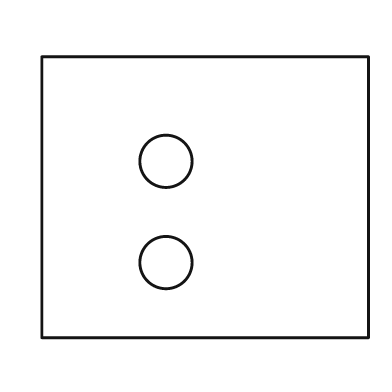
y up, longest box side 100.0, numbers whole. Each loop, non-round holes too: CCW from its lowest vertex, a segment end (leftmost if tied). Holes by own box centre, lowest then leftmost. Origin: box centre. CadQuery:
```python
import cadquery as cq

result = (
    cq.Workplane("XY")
    .moveTo(-50.0, -43.0)
    .lineTo(50.0, -43.0)
    .lineTo(50.0, 43.0)
    .lineTo(-50.0, 43.0)
    .close()
    .moveTo(-12.0, -20.0)
    .circle(8.0)
    .moveTo(-12.0, 11.0)
    .circle(8.0)
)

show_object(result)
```